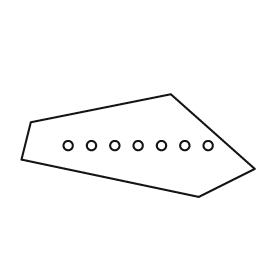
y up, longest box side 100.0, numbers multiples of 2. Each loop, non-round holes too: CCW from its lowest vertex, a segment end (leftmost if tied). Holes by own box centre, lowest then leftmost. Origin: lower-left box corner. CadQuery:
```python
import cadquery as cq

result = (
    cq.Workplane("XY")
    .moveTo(76.0, 0.0)
    .lineTo(100.0, 12.0)
    .lineTo(64.0, 44.0)
    .lineTo(4.0, 32.0)
    .lineTo(0.0, 16.0)
    .close()
    .moveTo(20.0, 22.0)
    .circle(2.0)
    .moveTo(30.0, 22.0)
    .circle(2.0)
    .moveTo(40.0, 22.0)
    .circle(2.0)
    .moveTo(50.0, 22.0)
    .circle(2.0)
    .moveTo(60.0, 22.0)
    .circle(2.0)
    .moveTo(70.0, 22.0)
    .circle(2.0)
    .moveTo(80.0, 22.0)
    .circle(2.0)
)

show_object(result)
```